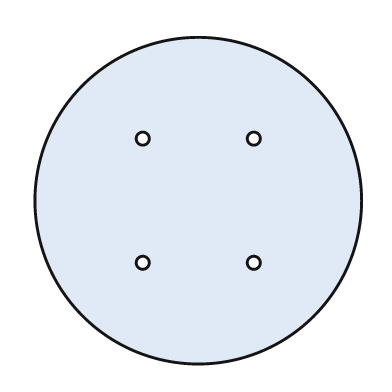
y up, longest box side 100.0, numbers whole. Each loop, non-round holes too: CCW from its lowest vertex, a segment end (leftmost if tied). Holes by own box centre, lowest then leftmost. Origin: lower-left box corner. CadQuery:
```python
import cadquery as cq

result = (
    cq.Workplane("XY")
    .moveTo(50.0, 50.0)
    .circle(50.0)
    .moveTo(33.0, 31.0)
    .circle(2.0)
    .moveTo(67.0, 31.0)
    .circle(2.0)
    .moveTo(33.0, 69.0)
    .circle(2.0)
    .moveTo(67.0, 69.0)
    .circle(2.0)
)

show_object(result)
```